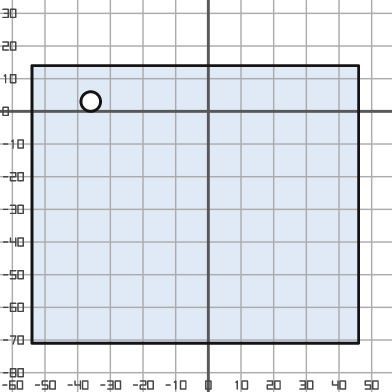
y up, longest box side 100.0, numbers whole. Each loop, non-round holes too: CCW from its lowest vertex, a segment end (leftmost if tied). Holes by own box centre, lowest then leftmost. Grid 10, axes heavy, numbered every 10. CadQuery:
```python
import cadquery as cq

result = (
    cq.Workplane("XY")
    .moveTo(-54.0, -71.0)
    .lineTo(46.0, -71.0)
    .lineTo(46.0, 14.0)
    .lineTo(-54.0, 14.0)
    .close()
    .moveTo(-36.0, 3.0)
    .circle(3.0)
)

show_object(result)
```